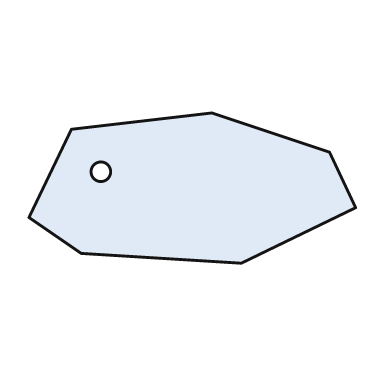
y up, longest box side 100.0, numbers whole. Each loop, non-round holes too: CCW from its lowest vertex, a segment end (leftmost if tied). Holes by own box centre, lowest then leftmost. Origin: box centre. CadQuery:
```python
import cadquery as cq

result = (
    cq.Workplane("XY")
    .moveTo(15.0, -23.0)
    .lineTo(50.0, -6.0)
    .lineTo(42.0, 11.0)
    .lineTo(6.0, 23.0)
    .lineTo(-37.0, 18.0)
    .lineTo(-50.0, -9.0)
    .lineTo(-34.0, -20.0)
    .close()
    .moveTo(-28.0, 5.0)
    .circle(3.0)
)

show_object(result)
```